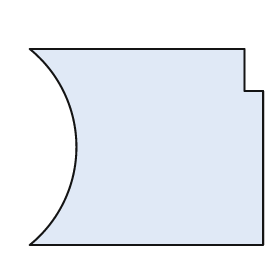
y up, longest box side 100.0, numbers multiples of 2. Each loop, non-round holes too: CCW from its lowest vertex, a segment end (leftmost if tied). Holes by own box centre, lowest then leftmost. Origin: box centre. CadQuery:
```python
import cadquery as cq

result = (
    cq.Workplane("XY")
    .moveTo(-50.0, -42.0)
    .lineTo(50.0, -42.0)
    .lineTo(50.0, 24.0)
    .lineTo(42.0, 24.0)
    .lineTo(42.0, 42.0)
    .lineTo(-50.0, 42.0)
    .threePointArc((-30.0, 0.0), (-50.0, -42.0))
    .close()
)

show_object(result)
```